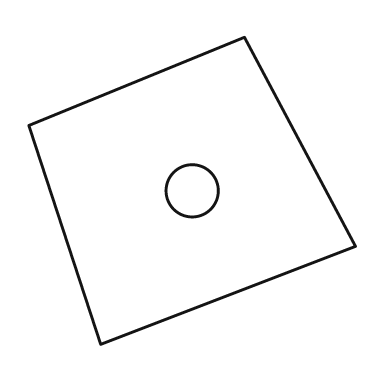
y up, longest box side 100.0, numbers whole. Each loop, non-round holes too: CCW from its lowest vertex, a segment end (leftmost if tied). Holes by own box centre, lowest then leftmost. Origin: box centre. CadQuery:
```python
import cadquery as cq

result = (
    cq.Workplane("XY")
    .moveTo(-28.0, -47.0)
    .lineTo(50.0, -17.0)
    .lineTo(16.0, 47.0)
    .lineTo(-50.0, 20.0)
    .close()
    .moveTo(0.0, 0.0)
    .circle(8.0)
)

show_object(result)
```